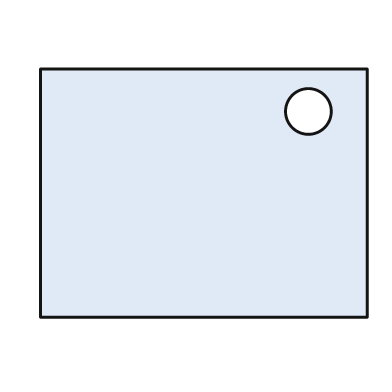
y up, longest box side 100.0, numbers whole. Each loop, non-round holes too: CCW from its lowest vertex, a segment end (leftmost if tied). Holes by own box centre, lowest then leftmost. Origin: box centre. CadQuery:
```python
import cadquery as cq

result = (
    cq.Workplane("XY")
    .moveTo(-50.0, -38.0)
    .lineTo(50.0, -38.0)
    .lineTo(50.0, 38.0)
    .lineTo(-50.0, 38.0)
    .close()
    .moveTo(32.0, 25.0)
    .circle(7.0)
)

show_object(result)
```